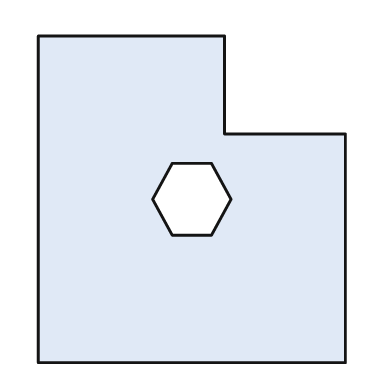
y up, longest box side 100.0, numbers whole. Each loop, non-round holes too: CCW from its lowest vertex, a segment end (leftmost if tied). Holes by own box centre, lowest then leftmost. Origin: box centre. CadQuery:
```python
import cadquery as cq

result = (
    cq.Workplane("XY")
    .moveTo(-47.0, -50.0)
    .lineTo(47.0, -50.0)
    .lineTo(47.0, 20.0)
    .lineTo(10.0, 20.0)
    .lineTo(10.0, 50.0)
    .lineTo(-47.0, 50.0)
    .close()
    .moveTo(-6.0, -11.0)
    .lineTo(6.0, -11.0)
    .lineTo(12.0, 0.0)
    .lineTo(6.0, 11.0)
    .lineTo(-6.0, 11.0)
    .lineTo(-12.0, 0.0)
    .close()
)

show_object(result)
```